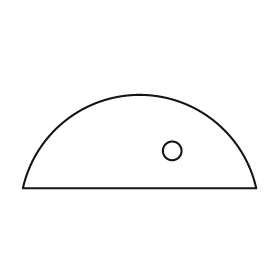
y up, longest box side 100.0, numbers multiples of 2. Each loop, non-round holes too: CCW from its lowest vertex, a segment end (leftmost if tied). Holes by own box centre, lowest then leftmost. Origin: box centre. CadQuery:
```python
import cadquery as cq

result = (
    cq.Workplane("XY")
    .moveTo(-50.0, -20.0)
    .lineTo(50.0, -20.0)
    .threePointArc((0.0, 20.0), (-50.0, -20.0))
    .close()
    .moveTo(14.0, -4.0)
    .circle(4.0)
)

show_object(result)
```